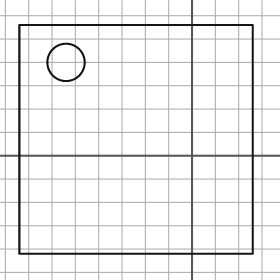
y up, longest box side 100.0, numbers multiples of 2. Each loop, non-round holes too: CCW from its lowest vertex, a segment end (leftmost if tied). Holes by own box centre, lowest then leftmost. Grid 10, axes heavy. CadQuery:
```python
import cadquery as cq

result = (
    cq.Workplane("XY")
    .moveTo(-74.0, -42.0)
    .lineTo(26.0, -42.0)
    .lineTo(26.0, 56.0)
    .lineTo(-74.0, 56.0)
    .close()
    .moveTo(-54.0, 40.0)
    .circle(8.0)
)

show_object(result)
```